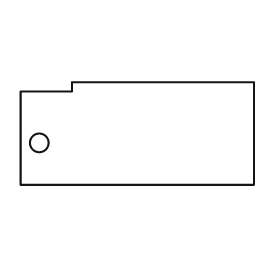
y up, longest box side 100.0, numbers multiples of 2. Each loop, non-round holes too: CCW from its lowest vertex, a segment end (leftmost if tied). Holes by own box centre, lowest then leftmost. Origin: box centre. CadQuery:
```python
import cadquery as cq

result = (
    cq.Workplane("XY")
    .moveTo(-50.0, -22.0)
    .lineTo(50.0, -22.0)
    .lineTo(50.0, 22.0)
    .lineTo(-28.0, 22.0)
    .lineTo(-28.0, 18.0)
    .lineTo(-50.0, 18.0)
    .close()
    .moveTo(-42.0, -4.0)
    .circle(4.0)
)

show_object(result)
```